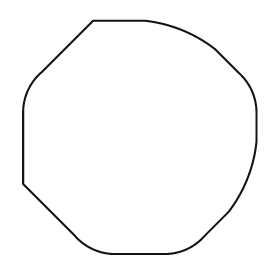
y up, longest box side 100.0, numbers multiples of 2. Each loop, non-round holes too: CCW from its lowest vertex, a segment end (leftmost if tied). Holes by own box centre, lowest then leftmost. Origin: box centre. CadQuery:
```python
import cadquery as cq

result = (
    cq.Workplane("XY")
    .moveTo(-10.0, -50.0)
    .lineTo(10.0, -50.0)
    .threePointArc((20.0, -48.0), (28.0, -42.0))
    .lineTo(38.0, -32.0)
    .threePointArc((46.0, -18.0), (50.0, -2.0))
    .lineTo(50.0, 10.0)
    .threePointArc((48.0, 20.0), (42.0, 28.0))
    .lineTo(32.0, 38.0)
    .threePointArc((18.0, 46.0), (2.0, 50.0))
    .lineTo(-20.0, 50.0)
    .lineTo(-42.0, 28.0)
    .threePointArc((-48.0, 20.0), (-50.0, 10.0))
    .lineTo(-50.0, -20.0)
    .lineTo(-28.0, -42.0)
    .threePointArc((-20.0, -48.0), (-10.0, -50.0))
    .close()
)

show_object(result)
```